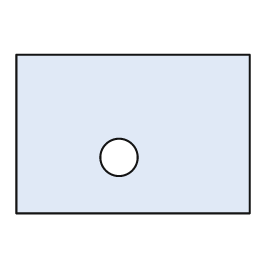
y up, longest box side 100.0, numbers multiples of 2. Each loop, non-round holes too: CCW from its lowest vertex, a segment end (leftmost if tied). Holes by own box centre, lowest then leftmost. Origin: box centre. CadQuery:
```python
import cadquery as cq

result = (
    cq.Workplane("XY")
    .moveTo(-50.0, -34.0)
    .lineTo(50.0, -34.0)
    .lineTo(50.0, 34.0)
    .lineTo(-50.0, 34.0)
    .close()
    .moveTo(-6.0, -10.0)
    .circle(8.0)
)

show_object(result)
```